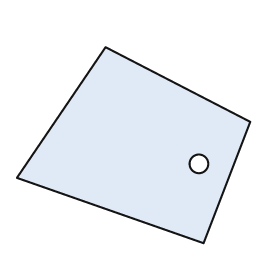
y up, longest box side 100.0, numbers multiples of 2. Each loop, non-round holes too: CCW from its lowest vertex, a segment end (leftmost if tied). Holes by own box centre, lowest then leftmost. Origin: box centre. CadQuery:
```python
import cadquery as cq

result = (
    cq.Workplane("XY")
    .moveTo(30.0, -42.0)
    .lineTo(50.0, 10.0)
    .lineTo(-12.0, 42.0)
    .lineTo(-50.0, -14.0)
    .close()
    .moveTo(28.0, -8.0)
    .circle(4.0)
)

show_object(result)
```